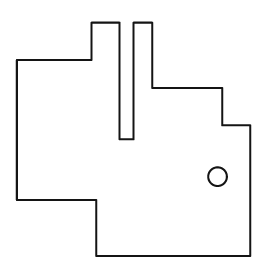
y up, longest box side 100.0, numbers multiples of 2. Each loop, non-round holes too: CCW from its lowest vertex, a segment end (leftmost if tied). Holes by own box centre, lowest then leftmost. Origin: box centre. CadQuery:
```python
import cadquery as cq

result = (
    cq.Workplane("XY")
    .moveTo(-16.0, -50.0)
    .lineTo(50.0, -50.0)
    .lineTo(50.0, 6.0)
    .lineTo(38.0, 6.0)
    .lineTo(38.0, 22.0)
    .lineTo(8.0, 22.0)
    .lineTo(8.0, 50.0)
    .lineTo(0.0, 50.0)
    .lineTo(0.0, 0.0)
    .lineTo(-6.0, 0.0)
    .lineTo(-6.0, 50.0)
    .lineTo(-18.0, 50.0)
    .lineTo(-18.0, 34.0)
    .lineTo(-50.0, 34.0)
    .lineTo(-50.0, -26.0)
    .lineTo(-16.0, -26.0)
    .close()
    .moveTo(36.0, -16.0)
    .circle(4.0)
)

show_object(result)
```